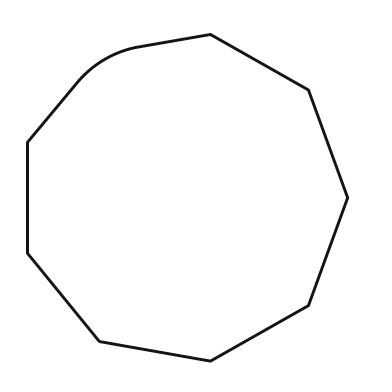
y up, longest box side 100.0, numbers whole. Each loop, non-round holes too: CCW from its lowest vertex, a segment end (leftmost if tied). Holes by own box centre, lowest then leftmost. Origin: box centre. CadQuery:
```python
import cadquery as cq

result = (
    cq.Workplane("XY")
    .moveTo(7.0, -50.0)
    .lineTo(37.0, -33.0)
    .lineTo(49.0, 0.0)
    .lineTo(37.0, 33.0)
    .lineTo(7.0, 50.0)
    .lineTo(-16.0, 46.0)
    .threePointArc((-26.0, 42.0), (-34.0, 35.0))
    .lineTo(-49.0, 17.0)
    .lineTo(-49.0, -17.0)
    .lineTo(-27.0, -44.0)
    .close()
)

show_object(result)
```